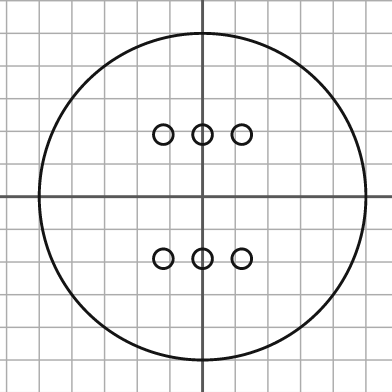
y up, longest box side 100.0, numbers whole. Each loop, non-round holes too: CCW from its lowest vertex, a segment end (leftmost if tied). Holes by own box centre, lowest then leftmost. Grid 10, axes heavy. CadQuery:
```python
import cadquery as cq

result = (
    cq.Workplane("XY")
    .moveTo(0.0, 0.0)
    .circle(50.0)
    .moveTo(-12.0, -19.0)
    .circle(3.0)
    .moveTo(0.0, -19.0)
    .circle(3.0)
    .moveTo(12.0, -19.0)
    .circle(3.0)
    .moveTo(-12.0, 19.0)
    .circle(3.0)
    .moveTo(0.0, 19.0)
    .circle(3.0)
    .moveTo(12.0, 19.0)
    .circle(3.0)
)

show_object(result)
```